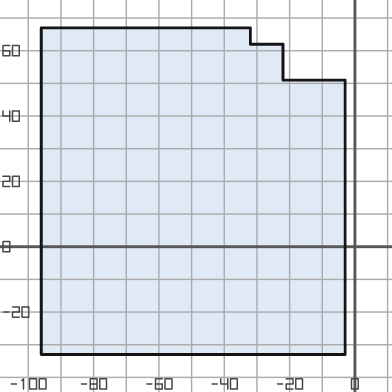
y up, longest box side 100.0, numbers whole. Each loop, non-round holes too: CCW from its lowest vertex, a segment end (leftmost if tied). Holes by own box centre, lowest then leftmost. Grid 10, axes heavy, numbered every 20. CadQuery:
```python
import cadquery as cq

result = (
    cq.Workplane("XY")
    .moveTo(-96.0, -33.0)
    .lineTo(-3.0, -33.0)
    .lineTo(-3.0, 51.0)
    .lineTo(-22.0, 51.0)
    .lineTo(-22.0, 62.0)
    .lineTo(-32.0, 62.0)
    .lineTo(-32.0, 67.0)
    .lineTo(-96.0, 67.0)
    .close()
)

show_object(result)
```